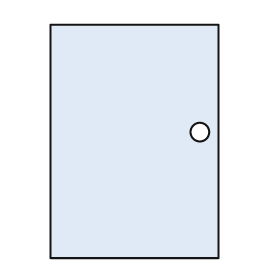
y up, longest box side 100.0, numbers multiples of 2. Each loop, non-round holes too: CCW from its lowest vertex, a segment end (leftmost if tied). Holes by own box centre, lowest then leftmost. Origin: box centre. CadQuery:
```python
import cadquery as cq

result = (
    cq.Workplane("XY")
    .moveTo(-36.0, -50.0)
    .lineTo(36.0, -50.0)
    .lineTo(36.0, 50.0)
    .lineTo(-36.0, 50.0)
    .close()
    .moveTo(28.0, 4.0)
    .circle(4.0)
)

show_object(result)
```